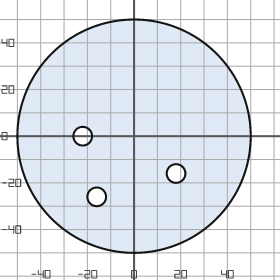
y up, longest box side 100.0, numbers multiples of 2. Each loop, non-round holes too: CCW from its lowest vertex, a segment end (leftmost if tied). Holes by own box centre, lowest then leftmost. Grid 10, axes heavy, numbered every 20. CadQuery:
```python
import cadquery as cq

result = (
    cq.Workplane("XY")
    .moveTo(0.0, 0.0)
    .circle(50.0)
    .moveTo(-16.0, -26.0)
    .circle(4.0)
    .moveTo(18.0, -16.0)
    .circle(4.0)
    .moveTo(-22.0, 0.0)
    .circle(4.0)
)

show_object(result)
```